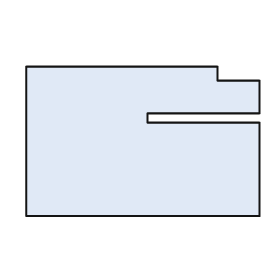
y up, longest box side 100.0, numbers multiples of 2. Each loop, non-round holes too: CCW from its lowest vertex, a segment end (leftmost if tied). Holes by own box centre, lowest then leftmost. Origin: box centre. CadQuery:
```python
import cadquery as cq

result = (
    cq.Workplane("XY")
    .moveTo(-50.0, -32.0)
    .lineTo(50.0, -32.0)
    .lineTo(50.0, 8.0)
    .lineTo(2.0, 8.0)
    .lineTo(2.0, 12.0)
    .lineTo(50.0, 12.0)
    .lineTo(50.0, 26.0)
    .lineTo(32.0, 26.0)
    .lineTo(32.0, 32.0)
    .lineTo(-50.0, 32.0)
    .close()
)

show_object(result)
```